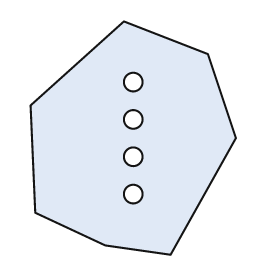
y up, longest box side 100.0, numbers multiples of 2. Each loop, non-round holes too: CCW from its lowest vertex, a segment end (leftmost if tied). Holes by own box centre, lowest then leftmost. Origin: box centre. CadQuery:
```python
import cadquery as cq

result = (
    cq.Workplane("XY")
    .moveTo(16.0, -50.0)
    .lineTo(44.0, 0.0)
    .lineTo(32.0, 36.0)
    .lineTo(-4.0, 50.0)
    .lineTo(-44.0, 14.0)
    .lineTo(-42.0, -32.0)
    .lineTo(-12.0, -46.0)
    .close()
    .moveTo(0.0, -24.0)
    .circle(4.0)
    .moveTo(0.0, -8.0)
    .circle(4.0)
    .moveTo(0.0, 8.0)
    .circle(4.0)
    .moveTo(0.0, 24.0)
    .circle(4.0)
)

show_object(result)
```